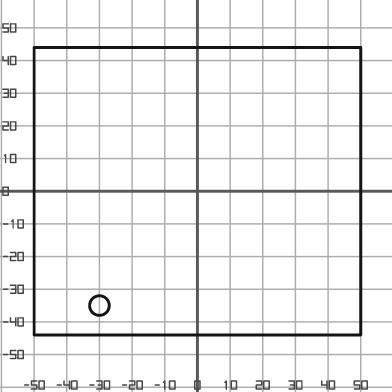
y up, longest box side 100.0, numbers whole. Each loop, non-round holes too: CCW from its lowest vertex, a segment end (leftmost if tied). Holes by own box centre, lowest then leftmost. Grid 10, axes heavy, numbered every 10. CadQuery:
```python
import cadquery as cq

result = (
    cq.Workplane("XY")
    .moveTo(-50.0, -44.0)
    .lineTo(50.0, -44.0)
    .lineTo(50.0, 44.0)
    .lineTo(-50.0, 44.0)
    .close()
    .moveTo(-30.0, -35.0)
    .circle(3.0)
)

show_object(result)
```